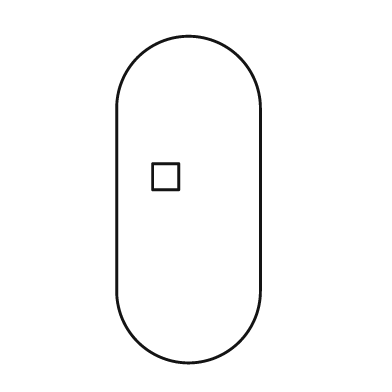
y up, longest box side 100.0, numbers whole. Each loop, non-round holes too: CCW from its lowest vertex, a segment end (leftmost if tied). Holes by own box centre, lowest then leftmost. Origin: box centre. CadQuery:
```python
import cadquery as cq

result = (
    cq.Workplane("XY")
    .moveTo(-22.0, -28.0)
    .threePointArc((0.0, -50.0), (22.0, -28.0))
    .lineTo(22.0, 28.0)
    .threePointArc((0.0, 50.0), (-22.0, 28.0))
    .close()
    .moveTo(-11.0, 3.0)
    .lineTo(-3.0, 3.0)
    .lineTo(-3.0, 11.0)
    .lineTo(-11.0, 11.0)
    .close()
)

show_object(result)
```